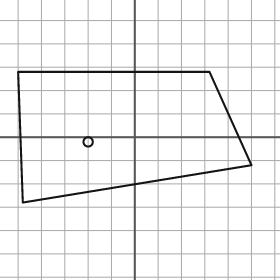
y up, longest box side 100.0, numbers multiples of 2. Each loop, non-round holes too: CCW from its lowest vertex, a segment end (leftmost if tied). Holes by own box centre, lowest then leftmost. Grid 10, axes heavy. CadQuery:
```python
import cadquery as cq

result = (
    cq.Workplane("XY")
    .moveTo(-48.0, -28.0)
    .lineTo(50.0, -12.0)
    .lineTo(32.0, 28.0)
    .lineTo(-50.0, 28.0)
    .close()
    .moveTo(-20.0, -2.0)
    .circle(2.0)
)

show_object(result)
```